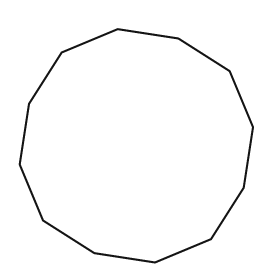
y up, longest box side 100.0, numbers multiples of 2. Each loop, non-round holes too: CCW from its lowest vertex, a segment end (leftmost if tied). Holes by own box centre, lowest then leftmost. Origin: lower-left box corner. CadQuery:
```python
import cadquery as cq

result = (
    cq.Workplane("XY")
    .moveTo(58.0, 0.0)
    .lineTo(82.0, 10.0)
    .lineTo(96.0, 32.0)
    .lineTo(100.0, 58.0)
    .lineTo(90.0, 82.0)
    .lineTo(68.0, 96.0)
    .lineTo(42.0, 100.0)
    .lineTo(18.0, 90.0)
    .lineTo(4.0, 68.0)
    .lineTo(0.0, 42.0)
    .lineTo(10.0, 18.0)
    .lineTo(32.0, 4.0)
    .close()
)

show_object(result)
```